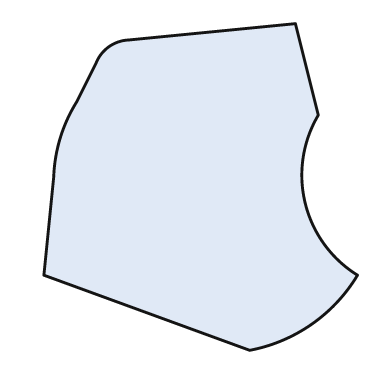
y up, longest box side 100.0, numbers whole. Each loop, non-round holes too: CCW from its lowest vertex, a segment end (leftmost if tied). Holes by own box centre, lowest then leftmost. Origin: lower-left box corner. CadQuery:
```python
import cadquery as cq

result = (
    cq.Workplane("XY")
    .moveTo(63.0, 0.0)
    .threePointArc((82.0, 8.0), (96.0, 23.0))
    .threePointArc((80.0, 45.0), (84.0, 72.0))
    .lineTo(77.0, 100.0)
    .lineTo(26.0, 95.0)
    .threePointArc((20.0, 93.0), (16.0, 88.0))
    .lineTo(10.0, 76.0)
    .threePointArc((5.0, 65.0), (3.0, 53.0))
    .lineTo(0.0, 23.0)
    .close()
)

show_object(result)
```